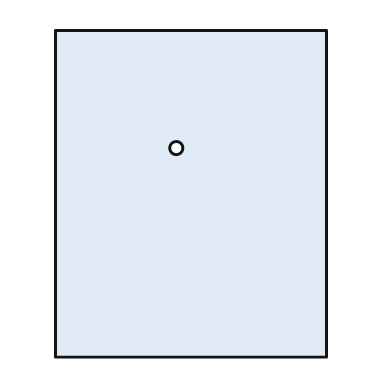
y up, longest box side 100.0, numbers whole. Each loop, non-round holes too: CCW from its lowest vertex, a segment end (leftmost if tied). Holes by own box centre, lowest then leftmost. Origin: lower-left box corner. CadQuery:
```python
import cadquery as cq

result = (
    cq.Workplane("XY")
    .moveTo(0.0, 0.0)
    .lineTo(83.0, 0.0)
    .lineTo(83.0, 100.0)
    .lineTo(0.0, 100.0)
    .close()
    .moveTo(37.0, 64.0)
    .circle(2.0)
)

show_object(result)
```